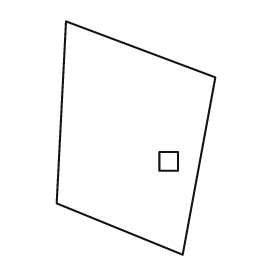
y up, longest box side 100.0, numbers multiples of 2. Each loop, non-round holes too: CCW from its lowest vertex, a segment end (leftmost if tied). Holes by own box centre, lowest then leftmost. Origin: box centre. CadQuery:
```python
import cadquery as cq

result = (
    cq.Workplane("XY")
    .moveTo(20.0, -50.0)
    .lineTo(34.0, 26.0)
    .lineTo(-30.0, 50.0)
    .lineTo(-34.0, -28.0)
    .close()
    .moveTo(10.0, -14.0)
    .lineTo(18.0, -14.0)
    .lineTo(18.0, -6.0)
    .lineTo(10.0, -6.0)
    .close()
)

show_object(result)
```